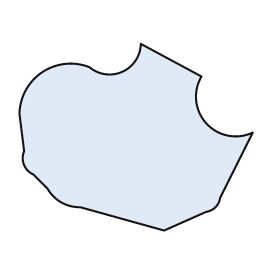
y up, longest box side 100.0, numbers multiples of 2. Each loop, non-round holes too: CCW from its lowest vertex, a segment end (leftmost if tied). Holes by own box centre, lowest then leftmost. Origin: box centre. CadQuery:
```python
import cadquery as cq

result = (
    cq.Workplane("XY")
    .moveTo(12.0, -40.0)
    .lineTo(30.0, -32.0)
    .threePointArc((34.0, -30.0), (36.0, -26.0))
    .lineTo(50.0, 2.0)
    .threePointArc((30.0, 6.0), (28.0, 26.0))
    .lineTo(2.0, 40.0)
    .threePointArc((-6.0, 28.0), (-20.0, 30.0))
    .threePointArc((-40.0, 28.0), (-50.0, 10.0))
    .lineTo(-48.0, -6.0)
    .threePointArc((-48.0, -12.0), (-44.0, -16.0))
    .lineTo(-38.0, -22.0)
    .threePointArc((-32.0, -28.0), (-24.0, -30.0))
    .close()
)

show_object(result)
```